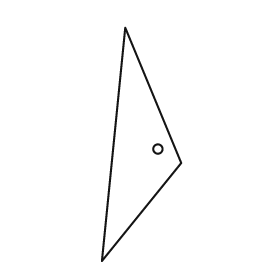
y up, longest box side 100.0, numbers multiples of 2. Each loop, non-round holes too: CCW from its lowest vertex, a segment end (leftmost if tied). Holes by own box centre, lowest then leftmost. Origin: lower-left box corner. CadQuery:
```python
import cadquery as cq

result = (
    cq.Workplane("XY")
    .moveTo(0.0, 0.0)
    .lineTo(34.0, 42.0)
    .lineTo(10.0, 100.0)
    .close()
    .moveTo(24.0, 48.0)
    .circle(2.0)
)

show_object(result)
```